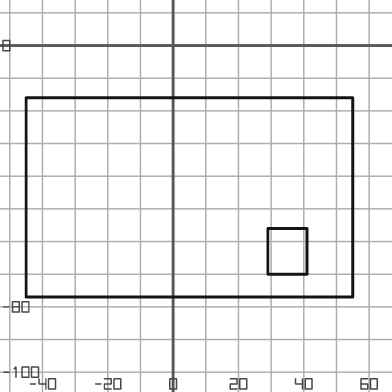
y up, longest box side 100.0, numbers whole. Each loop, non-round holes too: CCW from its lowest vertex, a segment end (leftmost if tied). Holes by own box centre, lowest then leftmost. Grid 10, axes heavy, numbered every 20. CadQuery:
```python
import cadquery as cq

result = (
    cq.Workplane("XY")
    .moveTo(-45.0, -77.0)
    .lineTo(55.0, -77.0)
    .lineTo(55.0, -16.0)
    .lineTo(-45.0, -16.0)
    .close()
    .moveTo(29.0, -70.0)
    .lineTo(41.0, -70.0)
    .lineTo(41.0, -56.0)
    .lineTo(29.0, -56.0)
    .close()
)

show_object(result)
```